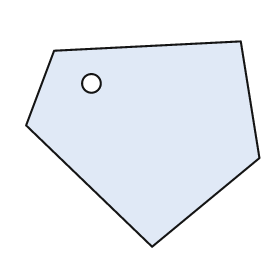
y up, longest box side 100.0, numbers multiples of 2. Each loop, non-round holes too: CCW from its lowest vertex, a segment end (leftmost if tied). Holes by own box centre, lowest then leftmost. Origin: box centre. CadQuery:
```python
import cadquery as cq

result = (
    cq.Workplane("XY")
    .moveTo(4.0, -44.0)
    .lineTo(50.0, -6.0)
    .lineTo(42.0, 44.0)
    .lineTo(-38.0, 40.0)
    .lineTo(-50.0, 8.0)
    .close()
    .moveTo(-22.0, 26.0)
    .circle(4.0)
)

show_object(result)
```